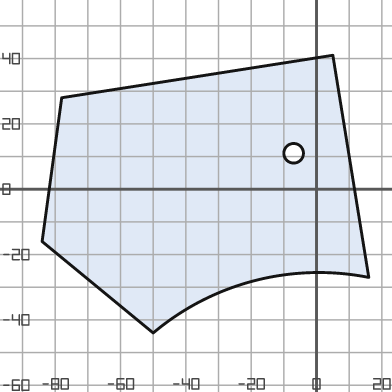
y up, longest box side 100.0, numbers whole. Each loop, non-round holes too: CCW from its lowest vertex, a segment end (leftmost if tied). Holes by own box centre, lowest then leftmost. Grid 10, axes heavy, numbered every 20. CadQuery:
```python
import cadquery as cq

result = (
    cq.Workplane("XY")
    .moveTo(-50.0, -44.0)
    .threePointArc((-19.0, -28.0), (16.0, -27.0))
    .lineTo(5.0, 41.0)
    .lineTo(-78.0, 28.0)
    .lineTo(-84.0, -16.0)
    .close()
    .moveTo(-7.0, 11.0)
    .circle(3.0)
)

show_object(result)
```